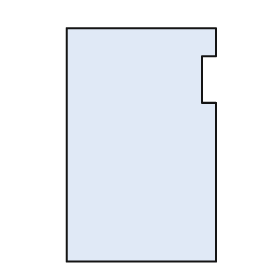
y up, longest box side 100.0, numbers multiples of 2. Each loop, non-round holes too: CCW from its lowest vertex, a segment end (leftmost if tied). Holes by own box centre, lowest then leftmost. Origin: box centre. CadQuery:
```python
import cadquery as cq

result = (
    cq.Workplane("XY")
    .moveTo(-32.0, -50.0)
    .lineTo(32.0, -50.0)
    .lineTo(32.0, 18.0)
    .lineTo(26.0, 18.0)
    .lineTo(26.0, 38.0)
    .lineTo(32.0, 38.0)
    .lineTo(32.0, 50.0)
    .lineTo(-32.0, 50.0)
    .close()
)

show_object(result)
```